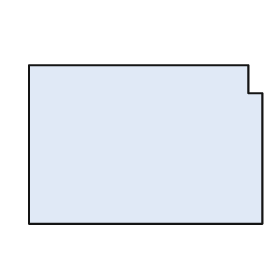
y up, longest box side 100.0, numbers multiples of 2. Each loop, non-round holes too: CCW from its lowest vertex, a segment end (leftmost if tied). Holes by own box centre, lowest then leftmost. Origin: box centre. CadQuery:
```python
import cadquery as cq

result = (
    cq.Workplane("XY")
    .moveTo(-50.0, -34.0)
    .lineTo(50.0, -34.0)
    .lineTo(50.0, 22.0)
    .lineTo(44.0, 22.0)
    .lineTo(44.0, 34.0)
    .lineTo(-50.0, 34.0)
    .close()
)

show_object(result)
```